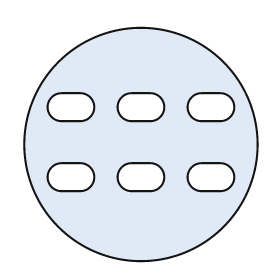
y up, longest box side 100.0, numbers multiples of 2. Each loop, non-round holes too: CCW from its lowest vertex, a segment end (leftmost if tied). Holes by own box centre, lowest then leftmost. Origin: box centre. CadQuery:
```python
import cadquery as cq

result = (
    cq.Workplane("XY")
    .moveTo(0.0, 0.0)
    .circle(50.0)
    .moveTo(-34.0, -20.0)
    .lineTo(-26.0, -20.0)
    .threePointArc((-20.0, -14.0), (-26.0, -8.0))
    .lineTo(-34.0, -8.0)
    .threePointArc((-40.0, -14.0), (-34.0, -20.0))
    .close()
    .moveTo(-4.0, -20.0)
    .lineTo(4.0, -20.0)
    .threePointArc((10.0, -14.0), (4.0, -8.0))
    .lineTo(-4.0, -8.0)
    .threePointArc((-10.0, -14.0), (-4.0, -20.0))
    .close()
    .moveTo(26.0, -20.0)
    .lineTo(34.0, -20.0)
    .threePointArc((40.0, -14.0), (34.0, -8.0))
    .lineTo(26.0, -8.0)
    .threePointArc((20.0, -14.0), (26.0, -20.0))
    .close()
    .moveTo(-34.0, 10.0)
    .lineTo(-26.0, 10.0)
    .threePointArc((-20.0, 16.0), (-26.0, 22.0))
    .lineTo(-34.0, 22.0)
    .threePointArc((-40.0, 16.0), (-34.0, 10.0))
    .close()
    .moveTo(-4.0, 10.0)
    .lineTo(4.0, 10.0)
    .threePointArc((10.0, 16.0), (4.0, 22.0))
    .lineTo(-4.0, 22.0)
    .threePointArc((-10.0, 16.0), (-4.0, 10.0))
    .close()
    .moveTo(26.0, 10.0)
    .lineTo(34.0, 10.0)
    .threePointArc((40.0, 16.0), (34.0, 22.0))
    .lineTo(26.0, 22.0)
    .threePointArc((20.0, 16.0), (26.0, 10.0))
    .close()
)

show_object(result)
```